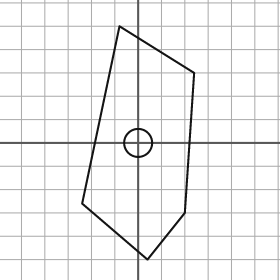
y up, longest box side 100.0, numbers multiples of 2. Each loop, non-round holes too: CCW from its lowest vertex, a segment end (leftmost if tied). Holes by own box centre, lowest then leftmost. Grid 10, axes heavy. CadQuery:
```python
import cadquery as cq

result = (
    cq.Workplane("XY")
    .moveTo(4.0, -50.0)
    .lineTo(20.0, -30.0)
    .lineTo(24.0, 30.0)
    .lineTo(-8.0, 50.0)
    .lineTo(-24.0, -26.0)
    .close()
    .moveTo(0.0, 0.0)
    .circle(6.0)
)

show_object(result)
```